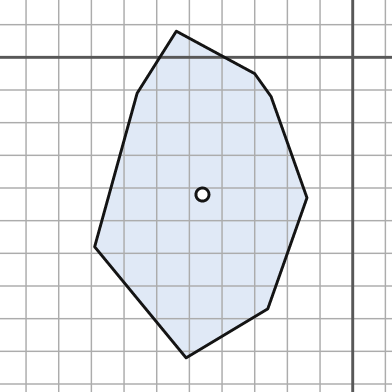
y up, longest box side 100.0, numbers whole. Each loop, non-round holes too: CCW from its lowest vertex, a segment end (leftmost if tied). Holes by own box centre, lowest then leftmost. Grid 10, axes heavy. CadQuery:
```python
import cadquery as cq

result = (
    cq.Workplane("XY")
    .moveTo(-51.0, -92.0)
    .lineTo(-26.0, -77.0)
    .lineTo(-14.0, -43.0)
    .lineTo(-25.0, -12.0)
    .lineTo(-30.0, -5.0)
    .lineTo(-54.0, 8.0)
    .lineTo(-66.0, -11.0)
    .lineTo(-79.0, -58.0)
    .close()
    .moveTo(-46.0, -42.0)
    .circle(2.0)
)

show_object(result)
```